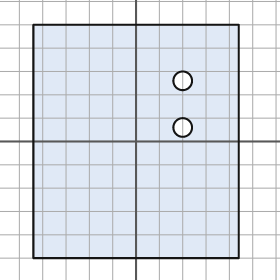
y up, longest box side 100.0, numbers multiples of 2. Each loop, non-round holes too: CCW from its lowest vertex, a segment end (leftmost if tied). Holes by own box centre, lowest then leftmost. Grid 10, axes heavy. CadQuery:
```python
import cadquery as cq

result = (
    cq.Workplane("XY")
    .moveTo(-44.0, -50.0)
    .lineTo(44.0, -50.0)
    .lineTo(44.0, 50.0)
    .lineTo(-44.0, 50.0)
    .close()
    .moveTo(20.0, 6.0)
    .circle(4.0)
    .moveTo(20.0, 26.0)
    .circle(4.0)
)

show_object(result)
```